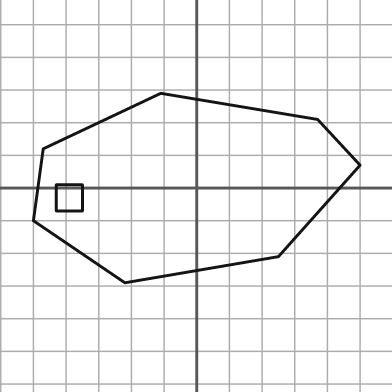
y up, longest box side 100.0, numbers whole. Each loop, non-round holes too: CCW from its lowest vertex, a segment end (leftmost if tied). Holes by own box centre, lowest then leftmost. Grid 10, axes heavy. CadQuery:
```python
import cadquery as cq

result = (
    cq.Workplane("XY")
    .moveTo(-22.0, -29.0)
    .lineTo(25.0, -21.0)
    .lineTo(50.0, 7.0)
    .lineTo(37.0, 21.0)
    .lineTo(-11.0, 29.0)
    .lineTo(-47.0, 12.0)
    .lineTo(-50.0, -10.0)
    .close()
    .moveTo(-43.0, -7.0)
    .lineTo(-35.0, -7.0)
    .lineTo(-35.0, 1.0)
    .lineTo(-43.0, 1.0)
    .close()
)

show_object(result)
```